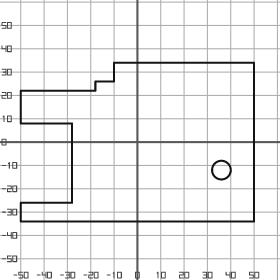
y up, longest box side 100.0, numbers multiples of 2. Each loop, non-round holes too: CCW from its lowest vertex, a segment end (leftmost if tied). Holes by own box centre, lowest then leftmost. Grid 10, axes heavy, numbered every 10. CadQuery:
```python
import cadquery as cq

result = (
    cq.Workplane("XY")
    .moveTo(-50.0, -34.0)
    .lineTo(50.0, -34.0)
    .lineTo(50.0, 34.0)
    .lineTo(-10.0, 34.0)
    .lineTo(-10.0, 26.0)
    .lineTo(-18.0, 26.0)
    .lineTo(-18.0, 22.0)
    .lineTo(-50.0, 22.0)
    .lineTo(-50.0, 8.0)
    .lineTo(-28.0, 8.0)
    .lineTo(-28.0, -26.0)
    .lineTo(-50.0, -26.0)
    .close()
    .moveTo(36.0, -12.0)
    .circle(4.0)
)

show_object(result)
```